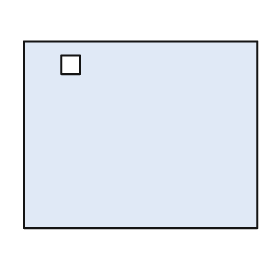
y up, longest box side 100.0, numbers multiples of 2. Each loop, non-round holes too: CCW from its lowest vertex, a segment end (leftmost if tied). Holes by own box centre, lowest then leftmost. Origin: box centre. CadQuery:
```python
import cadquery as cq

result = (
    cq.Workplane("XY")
    .moveTo(-50.0, -40.0)
    .lineTo(50.0, -40.0)
    .lineTo(50.0, 40.0)
    .lineTo(-50.0, 40.0)
    .close()
    .moveTo(-34.0, 26.0)
    .lineTo(-26.0, 26.0)
    .lineTo(-26.0, 34.0)
    .lineTo(-34.0, 34.0)
    .close()
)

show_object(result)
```